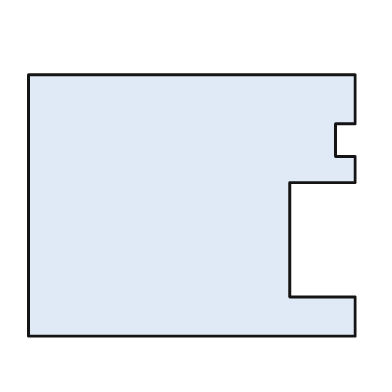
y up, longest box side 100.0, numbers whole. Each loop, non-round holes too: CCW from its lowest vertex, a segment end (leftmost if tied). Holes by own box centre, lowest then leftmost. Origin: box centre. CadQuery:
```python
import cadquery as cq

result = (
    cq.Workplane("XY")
    .moveTo(-50.0, -40.0)
    .lineTo(50.0, -40.0)
    .lineTo(50.0, -28.0)
    .lineTo(30.0, -28.0)
    .lineTo(30.0, 7.0)
    .lineTo(50.0, 7.0)
    .lineTo(50.0, 15.0)
    .lineTo(44.0, 15.0)
    .lineTo(44.0, 25.0)
    .lineTo(50.0, 25.0)
    .lineTo(50.0, 40.0)
    .lineTo(-50.0, 40.0)
    .close()
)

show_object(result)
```